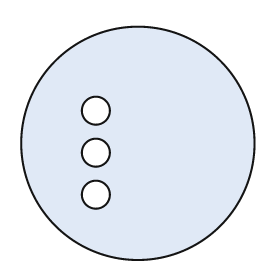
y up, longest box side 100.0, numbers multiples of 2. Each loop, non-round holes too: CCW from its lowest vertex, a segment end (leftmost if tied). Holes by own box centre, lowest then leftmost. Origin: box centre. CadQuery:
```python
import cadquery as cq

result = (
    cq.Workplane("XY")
    .moveTo(0.0, 0.0)
    .circle(50.0)
    .moveTo(-18.0, -22.0)
    .circle(6.0)
    .moveTo(-18.0, -4.0)
    .circle(6.0)
    .moveTo(-18.0, 14.0)
    .circle(6.0)
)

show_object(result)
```